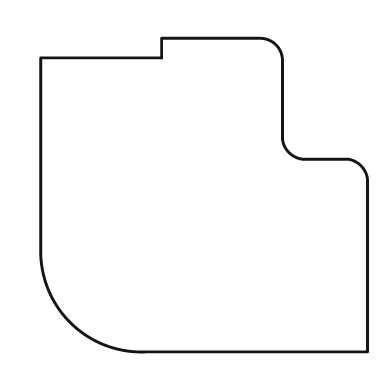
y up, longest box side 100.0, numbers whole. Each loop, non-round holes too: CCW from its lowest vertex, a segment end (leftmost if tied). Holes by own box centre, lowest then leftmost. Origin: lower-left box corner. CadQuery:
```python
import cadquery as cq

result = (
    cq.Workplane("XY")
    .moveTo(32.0, 0.0)
    .lineTo(100.0, 0.0)
    .lineTo(100.0, 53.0)
    .threePointArc((98.0, 57.0), (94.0, 59.0))
    .lineTo(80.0, 59.0)
    .threePointArc((76.0, 61.0), (74.0, 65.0))
    .lineTo(74.0, 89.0)
    .threePointArc((72.0, 94.0), (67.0, 96.0))
    .lineTo(37.0, 96.0)
    .lineTo(37.0, 90.0)
    .lineTo(0.0, 90.0)
    .lineTo(0.0, 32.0)
    .threePointArc((9.0, 9.0), (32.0, 0.0))
    .close()
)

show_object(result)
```